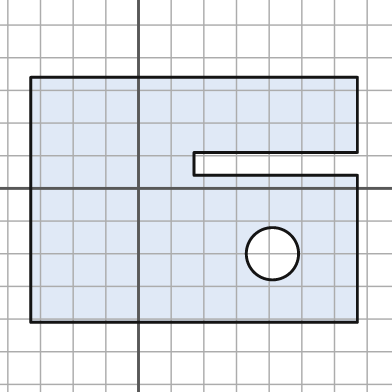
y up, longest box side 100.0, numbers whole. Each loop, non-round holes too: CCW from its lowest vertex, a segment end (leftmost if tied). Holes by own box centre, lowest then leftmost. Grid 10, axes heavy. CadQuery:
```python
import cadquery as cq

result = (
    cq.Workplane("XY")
    .moveTo(-33.0, -41.0)
    .lineTo(67.0, -41.0)
    .lineTo(67.0, 4.0)
    .lineTo(17.0, 4.0)
    .lineTo(17.0, 11.0)
    .lineTo(67.0, 11.0)
    .lineTo(67.0, 34.0)
    .lineTo(-33.0, 34.0)
    .close()
    .moveTo(41.0, -20.0)
    .circle(8.0)
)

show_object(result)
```